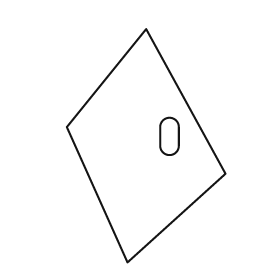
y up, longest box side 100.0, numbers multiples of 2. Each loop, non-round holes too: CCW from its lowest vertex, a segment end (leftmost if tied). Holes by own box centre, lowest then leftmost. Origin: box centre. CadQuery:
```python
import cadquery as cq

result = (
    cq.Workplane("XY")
    .moveTo(-8.0, -50.0)
    .lineTo(34.0, -12.0)
    .lineTo(0.0, 50.0)
    .lineTo(-34.0, 8.0)
    .close()
    .moveTo(6.0, 0.0)
    .threePointArc((10.0, -4.0), (14.0, 0.0))
    .lineTo(14.0, 8.0)
    .threePointArc((10.0, 12.0), (6.0, 8.0))
    .close()
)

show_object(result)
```